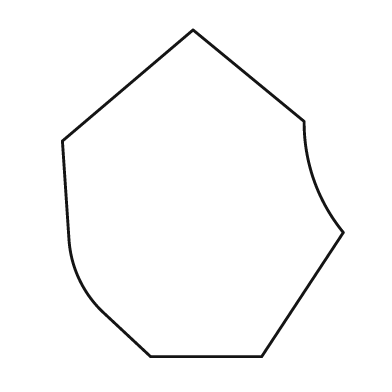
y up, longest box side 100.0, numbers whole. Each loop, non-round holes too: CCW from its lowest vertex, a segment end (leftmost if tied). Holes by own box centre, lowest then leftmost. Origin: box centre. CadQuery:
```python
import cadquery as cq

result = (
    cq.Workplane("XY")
    .moveTo(-16.0, -50.0)
    .lineTo(18.0, -50.0)
    .lineTo(43.0, -12.0)
    .threePointArc((34.0, 4.0), (31.0, 22.0))
    .lineTo(-3.0, 50.0)
    .lineTo(-43.0, 16.0)
    .lineTo(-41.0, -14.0)
    .threePointArc((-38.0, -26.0), (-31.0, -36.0))
    .close()
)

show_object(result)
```